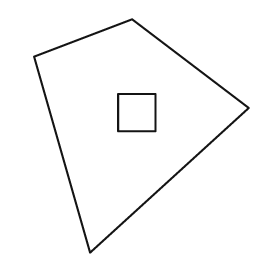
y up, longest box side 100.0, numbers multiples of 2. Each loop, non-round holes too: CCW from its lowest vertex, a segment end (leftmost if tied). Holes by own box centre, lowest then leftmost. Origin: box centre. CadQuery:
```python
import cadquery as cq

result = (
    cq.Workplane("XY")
    .moveTo(-22.0, -50.0)
    .lineTo(46.0, 12.0)
    .lineTo(-4.0, 50.0)
    .lineTo(-46.0, 34.0)
    .close()
    .moveTo(-10.0, 2.0)
    .lineTo(6.0, 2.0)
    .lineTo(6.0, 18.0)
    .lineTo(-10.0, 18.0)
    .close()
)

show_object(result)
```